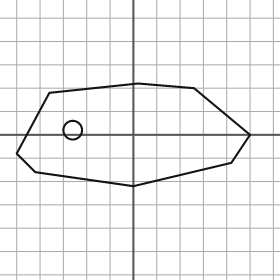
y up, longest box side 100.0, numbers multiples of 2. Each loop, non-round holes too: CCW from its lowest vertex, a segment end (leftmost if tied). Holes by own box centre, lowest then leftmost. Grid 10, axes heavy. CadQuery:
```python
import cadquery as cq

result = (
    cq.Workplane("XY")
    .moveTo(0.0, -22.0)
    .lineTo(42.0, -12.0)
    .lineTo(50.0, 0.0)
    .lineTo(26.0, 20.0)
    .lineTo(2.0, 22.0)
    .lineTo(-36.0, 18.0)
    .lineTo(-50.0, -8.0)
    .lineTo(-42.0, -16.0)
    .close()
    .moveTo(-26.0, 2.0)
    .circle(4.0)
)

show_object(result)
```